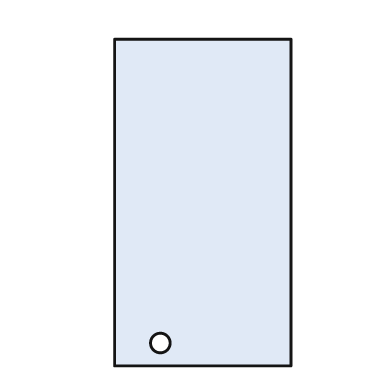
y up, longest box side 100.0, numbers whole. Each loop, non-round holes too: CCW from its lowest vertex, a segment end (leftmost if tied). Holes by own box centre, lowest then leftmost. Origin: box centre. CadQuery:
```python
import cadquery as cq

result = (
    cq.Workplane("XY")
    .moveTo(-27.0, -50.0)
    .lineTo(27.0, -50.0)
    .lineTo(27.0, 50.0)
    .lineTo(-27.0, 50.0)
    .close()
    .moveTo(-13.0, -43.0)
    .circle(3.0)
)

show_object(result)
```